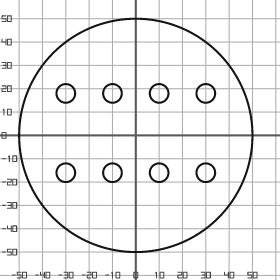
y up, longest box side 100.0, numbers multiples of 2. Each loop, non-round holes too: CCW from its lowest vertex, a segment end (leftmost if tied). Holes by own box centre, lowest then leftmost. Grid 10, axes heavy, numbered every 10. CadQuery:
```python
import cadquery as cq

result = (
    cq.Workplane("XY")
    .moveTo(0.0, 0.0)
    .circle(50.0)
    .moveTo(-30.0, -16.0)
    .circle(4.0)
    .moveTo(-10.0, -16.0)
    .circle(4.0)
    .moveTo(10.0, -16.0)
    .circle(4.0)
    .moveTo(30.0, -16.0)
    .circle(4.0)
    .moveTo(-30.0, 18.0)
    .circle(4.0)
    .moveTo(-10.0, 18.0)
    .circle(4.0)
    .moveTo(10.0, 18.0)
    .circle(4.0)
    .moveTo(30.0, 18.0)
    .circle(4.0)
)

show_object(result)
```